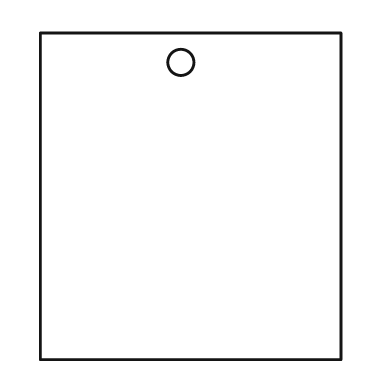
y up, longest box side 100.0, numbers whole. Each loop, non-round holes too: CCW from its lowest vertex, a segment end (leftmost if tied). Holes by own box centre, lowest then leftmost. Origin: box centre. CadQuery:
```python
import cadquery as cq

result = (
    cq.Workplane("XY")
    .moveTo(-46.0, -50.0)
    .lineTo(46.0, -50.0)
    .lineTo(46.0, 50.0)
    .lineTo(-46.0, 50.0)
    .close()
    .moveTo(-3.0, 41.0)
    .circle(4.0)
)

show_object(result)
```